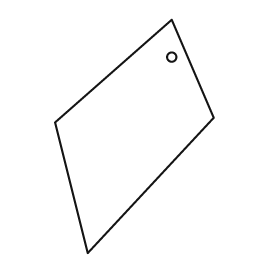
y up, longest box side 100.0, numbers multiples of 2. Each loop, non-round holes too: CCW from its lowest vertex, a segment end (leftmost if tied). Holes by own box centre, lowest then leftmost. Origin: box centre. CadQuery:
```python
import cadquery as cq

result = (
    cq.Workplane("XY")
    .moveTo(-20.0, -50.0)
    .lineTo(34.0, 8.0)
    .lineTo(16.0, 50.0)
    .lineTo(-34.0, 6.0)
    .close()
    .moveTo(16.0, 34.0)
    .circle(2.0)
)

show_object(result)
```